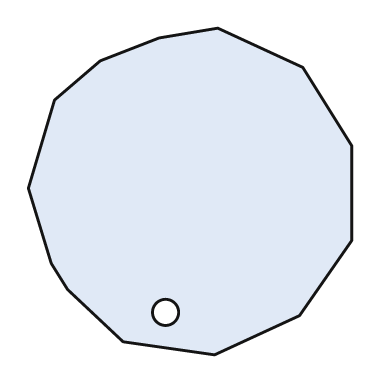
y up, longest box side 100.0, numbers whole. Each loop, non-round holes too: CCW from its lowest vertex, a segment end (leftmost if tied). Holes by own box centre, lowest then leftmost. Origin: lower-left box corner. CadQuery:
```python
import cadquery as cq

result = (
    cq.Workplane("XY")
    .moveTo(57.0, 0.0)
    .lineTo(83.0, 12.0)
    .lineTo(99.0, 35.0)
    .lineTo(99.0, 64.0)
    .lineTo(84.0, 88.0)
    .lineTo(58.0, 100.0)
    .lineTo(40.0, 97.0)
    .lineTo(22.0, 90.0)
    .lineTo(8.0, 78.0)
    .lineTo(0.0, 51.0)
    .lineTo(7.0, 28.0)
    .lineTo(12.0, 20.0)
    .lineTo(29.0, 4.0)
    .close()
    .moveTo(42.0, 13.0)
    .circle(4.0)
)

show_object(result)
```